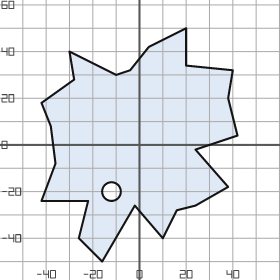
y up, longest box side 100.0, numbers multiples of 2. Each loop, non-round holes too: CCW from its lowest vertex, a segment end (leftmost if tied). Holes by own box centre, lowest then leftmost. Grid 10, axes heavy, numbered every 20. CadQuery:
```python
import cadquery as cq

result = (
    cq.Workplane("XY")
    .moveTo(-16.0, -50.0)
    .lineTo(-2.0, -26.0)
    .lineTo(10.0, -40.0)
    .lineTo(16.0, -28.0)
    .lineTo(24.0, -26.0)
    .lineTo(38.0, -18.0)
    .lineTo(24.0, -2.0)
    .lineTo(42.0, 4.0)
    .lineTo(38.0, 20.0)
    .lineTo(40.0, 32.0)
    .lineTo(20.0, 34.0)
    .lineTo(20.0, 50.0)
    .lineTo(4.0, 42.0)
    .lineTo(-4.0, 32.0)
    .lineTo(-10.0, 30.0)
    .lineTo(-30.0, 40.0)
    .lineTo(-28.0, 28.0)
    .lineTo(-42.0, 18.0)
    .lineTo(-38.0, 8.0)
    .lineTo(-36.0, -8.0)
    .lineTo(-42.0, -24.0)
    .lineTo(-22.0, -24.0)
    .lineTo(-26.0, -40.0)
    .close()
    .moveTo(-12.0, -20.0)
    .circle(4.0)
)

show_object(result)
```